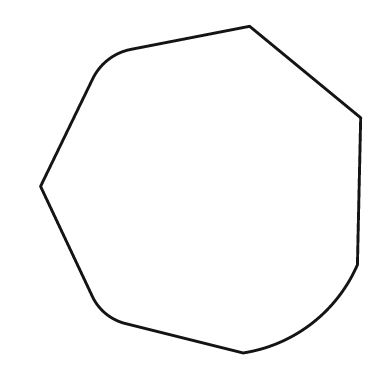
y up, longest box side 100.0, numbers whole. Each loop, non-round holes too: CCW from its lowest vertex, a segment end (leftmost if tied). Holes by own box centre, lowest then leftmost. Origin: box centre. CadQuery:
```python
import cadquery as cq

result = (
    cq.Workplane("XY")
    .moveTo(13.0, -50.0)
    .threePointArc((34.0, -41.0), (48.0, -23.0))
    .lineTo(49.0, 22.0)
    .lineTo(15.0, 50.0)
    .lineTo(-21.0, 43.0)
    .threePointArc((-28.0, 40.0), (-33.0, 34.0))
    .lineTo(-49.0, 1.0)
    .lineTo(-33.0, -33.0)
    .threePointArc((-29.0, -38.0), (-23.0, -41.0))
    .close()
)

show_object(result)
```